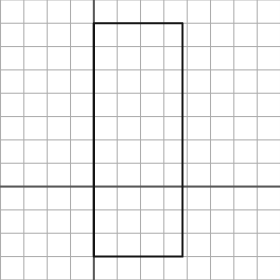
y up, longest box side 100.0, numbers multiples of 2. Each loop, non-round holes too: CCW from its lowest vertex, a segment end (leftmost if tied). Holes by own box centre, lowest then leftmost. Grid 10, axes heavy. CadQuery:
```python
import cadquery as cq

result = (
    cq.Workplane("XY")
    .moveTo(0.0, -30.0)
    .lineTo(38.0, -30.0)
    .lineTo(38.0, 70.0)
    .lineTo(0.0, 70.0)
    .close()
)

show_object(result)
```